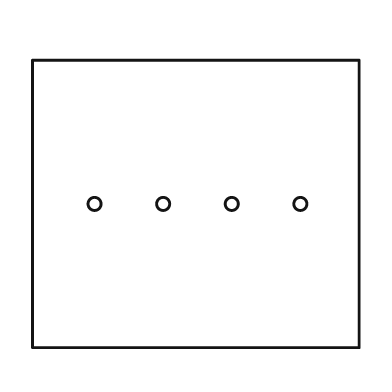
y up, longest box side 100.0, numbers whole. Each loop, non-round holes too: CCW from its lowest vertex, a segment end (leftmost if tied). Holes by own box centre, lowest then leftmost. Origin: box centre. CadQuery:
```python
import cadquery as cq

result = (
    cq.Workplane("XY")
    .moveTo(-50.0, -44.0)
    .lineTo(50.0, -44.0)
    .lineTo(50.0, 44.0)
    .lineTo(-50.0, 44.0)
    .close()
    .moveTo(-31.0, 0.0)
    .circle(2.0)
    .moveTo(-10.0, 0.0)
    .circle(2.0)
    .moveTo(11.0, 0.0)
    .circle(2.0)
    .moveTo(32.0, 0.0)
    .circle(2.0)
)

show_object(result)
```